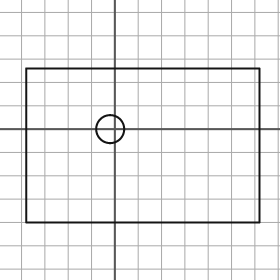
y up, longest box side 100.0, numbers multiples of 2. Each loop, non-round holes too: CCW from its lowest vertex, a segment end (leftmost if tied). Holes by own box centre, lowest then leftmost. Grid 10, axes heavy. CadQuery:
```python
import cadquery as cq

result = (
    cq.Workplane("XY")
    .moveTo(-38.0, -40.0)
    .lineTo(62.0, -40.0)
    .lineTo(62.0, 26.0)
    .lineTo(-38.0, 26.0)
    .close()
    .moveTo(-2.0, 0.0)
    .circle(6.0)
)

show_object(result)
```